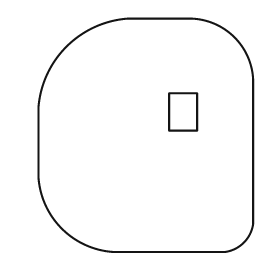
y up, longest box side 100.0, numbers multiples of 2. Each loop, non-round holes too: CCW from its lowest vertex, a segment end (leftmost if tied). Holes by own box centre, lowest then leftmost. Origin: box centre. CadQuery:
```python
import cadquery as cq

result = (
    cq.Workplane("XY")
    .moveTo(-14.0, -50.0)
    .lineTo(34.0, -50.0)
    .threePointArc((42.0, -46.0), (46.0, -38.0))
    .lineTo(46.0, 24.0)
    .threePointArc((38.0, 42.0), (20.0, 50.0))
    .lineTo(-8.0, 50.0)
    .threePointArc((-34.0, 38.0), (-46.0, 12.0))
    .lineTo(-46.0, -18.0)
    .threePointArc((-36.0, -40.0), (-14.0, -50.0))
    .close()
    .moveTo(10.0, 2.0)
    .lineTo(22.0, 2.0)
    .lineTo(22.0, 18.0)
    .lineTo(10.0, 18.0)
    .close()
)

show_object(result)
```